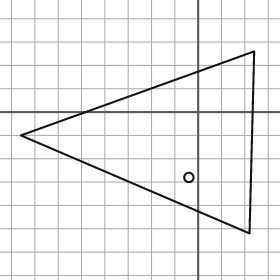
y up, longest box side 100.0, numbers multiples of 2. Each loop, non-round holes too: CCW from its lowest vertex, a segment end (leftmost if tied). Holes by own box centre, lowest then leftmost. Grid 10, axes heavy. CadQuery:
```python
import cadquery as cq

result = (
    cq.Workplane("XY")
    .moveTo(22.0, -52.0)
    .lineTo(24.0, 26.0)
    .lineTo(-76.0, -10.0)
    .close()
    .moveTo(-4.0, -28.0)
    .circle(2.0)
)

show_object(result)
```